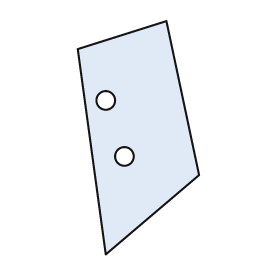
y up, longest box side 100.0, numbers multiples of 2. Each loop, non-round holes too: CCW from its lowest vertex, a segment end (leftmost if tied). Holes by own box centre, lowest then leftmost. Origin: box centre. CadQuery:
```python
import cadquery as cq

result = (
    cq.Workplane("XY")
    .moveTo(-14.0, -50.0)
    .lineTo(26.0, -16.0)
    .lineTo(12.0, 50.0)
    .lineTo(-26.0, 38.0)
    .close()
    .moveTo(-6.0, -8.0)
    .circle(4.0)
    .moveTo(-14.0, 16.0)
    .circle(4.0)
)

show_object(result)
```